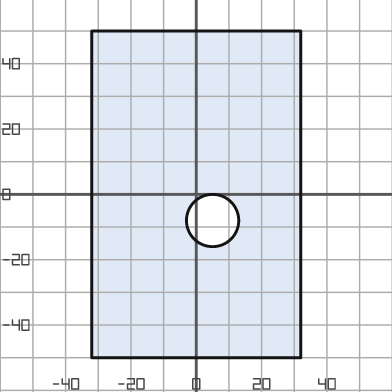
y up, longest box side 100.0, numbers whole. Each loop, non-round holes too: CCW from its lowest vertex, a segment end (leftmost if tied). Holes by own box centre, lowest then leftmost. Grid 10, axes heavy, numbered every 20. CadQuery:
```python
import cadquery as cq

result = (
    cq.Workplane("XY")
    .moveTo(-32.0, -50.0)
    .lineTo(32.0, -50.0)
    .lineTo(32.0, 50.0)
    .lineTo(-32.0, 50.0)
    .close()
    .moveTo(5.0, -8.0)
    .circle(8.0)
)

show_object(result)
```